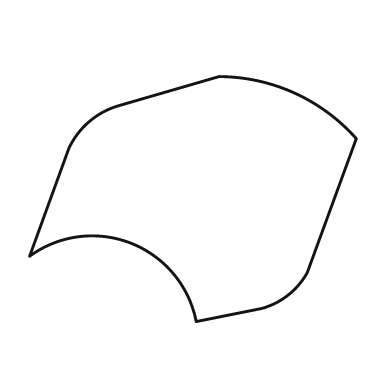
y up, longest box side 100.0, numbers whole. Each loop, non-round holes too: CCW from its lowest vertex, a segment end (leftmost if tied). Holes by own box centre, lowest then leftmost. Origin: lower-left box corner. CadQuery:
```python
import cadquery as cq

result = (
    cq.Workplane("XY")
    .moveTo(51.0, 0.0)
    .lineTo(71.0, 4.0)
    .threePointArc((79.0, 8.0), (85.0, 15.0))
    .lineTo(100.0, 56.0)
    .threePointArc((81.0, 70.0), (58.0, 75.0))
    .lineTo(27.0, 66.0)
    .threePointArc((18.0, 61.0), (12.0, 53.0))
    .lineTo(0.0, 20.0)
    .threePointArc((31.0, 24.0), (51.0, 0.0))
    .close()
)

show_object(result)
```